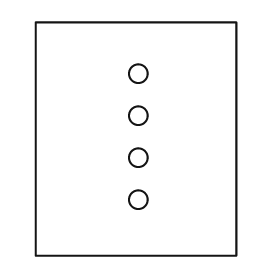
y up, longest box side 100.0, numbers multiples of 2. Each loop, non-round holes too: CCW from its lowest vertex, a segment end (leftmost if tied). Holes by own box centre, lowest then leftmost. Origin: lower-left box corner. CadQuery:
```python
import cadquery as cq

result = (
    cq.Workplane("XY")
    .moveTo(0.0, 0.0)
    .lineTo(86.0, 0.0)
    .lineTo(86.0, 100.0)
    .lineTo(0.0, 100.0)
    .close()
    .moveTo(44.0, 24.0)
    .circle(4.0)
    .moveTo(44.0, 42.0)
    .circle(4.0)
    .moveTo(44.0, 60.0)
    .circle(4.0)
    .moveTo(44.0, 78.0)
    .circle(4.0)
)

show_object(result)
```